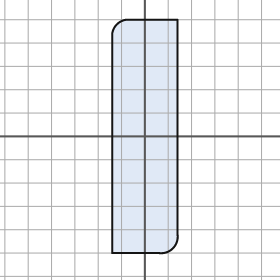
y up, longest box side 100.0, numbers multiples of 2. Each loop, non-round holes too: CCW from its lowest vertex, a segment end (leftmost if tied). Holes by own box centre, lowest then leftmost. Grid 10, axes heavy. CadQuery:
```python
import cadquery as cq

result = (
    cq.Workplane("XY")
    .moveTo(-14.0, -50.0)
    .lineTo(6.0, -50.0)
    .threePointArc((12.0, -48.0), (14.0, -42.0))
    .lineTo(14.0, 50.0)
    .lineTo(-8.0, 50.0)
    .threePointArc((-12.0, 48.0), (-14.0, 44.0))
    .close()
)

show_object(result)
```